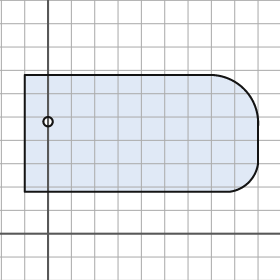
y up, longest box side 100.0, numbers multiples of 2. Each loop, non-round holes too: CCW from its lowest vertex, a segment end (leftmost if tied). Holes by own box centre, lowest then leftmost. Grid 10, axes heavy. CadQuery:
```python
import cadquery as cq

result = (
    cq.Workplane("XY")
    .moveTo(-10.0, 18.0)
    .lineTo(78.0, 18.0)
    .threePointArc((86.0, 22.0), (90.0, 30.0))
    .lineTo(90.0, 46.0)
    .threePointArc((84.0, 62.0), (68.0, 68.0))
    .lineTo(-10.0, 68.0)
    .close()
    .moveTo(0.0, 48.0)
    .circle(2.0)
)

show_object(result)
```